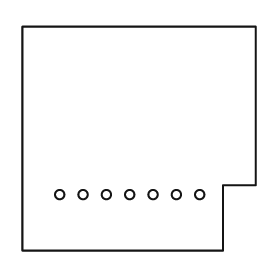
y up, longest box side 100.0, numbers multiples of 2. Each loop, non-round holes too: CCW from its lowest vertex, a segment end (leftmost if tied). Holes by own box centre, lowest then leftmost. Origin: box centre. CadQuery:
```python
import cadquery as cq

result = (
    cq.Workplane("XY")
    .moveTo(-50.0, -48.0)
    .lineTo(36.0, -48.0)
    .lineTo(36.0, -20.0)
    .lineTo(50.0, -20.0)
    .lineTo(50.0, 48.0)
    .lineTo(-50.0, 48.0)
    .close()
    .moveTo(-34.0, -24.0)
    .circle(2.0)
    .moveTo(-24.0, -24.0)
    .circle(2.0)
    .moveTo(-14.0, -24.0)
    .circle(2.0)
    .moveTo(-4.0, -24.0)
    .circle(2.0)
    .moveTo(6.0, -24.0)
    .circle(2.0)
    .moveTo(16.0, -24.0)
    .circle(2.0)
    .moveTo(26.0, -24.0)
    .circle(2.0)
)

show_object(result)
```